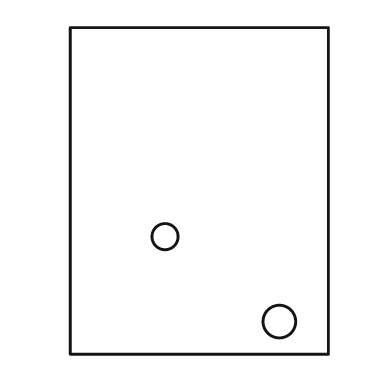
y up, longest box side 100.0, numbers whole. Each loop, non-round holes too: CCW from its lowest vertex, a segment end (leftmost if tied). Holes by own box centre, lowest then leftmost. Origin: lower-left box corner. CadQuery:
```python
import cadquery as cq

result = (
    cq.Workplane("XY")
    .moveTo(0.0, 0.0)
    .lineTo(79.0, 0.0)
    .lineTo(79.0, 100.0)
    .lineTo(0.0, 100.0)
    .close()
    .moveTo(64.0, 10.0)
    .circle(5.0)
    .moveTo(29.0, 36.0)
    .circle(4.0)
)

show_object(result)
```